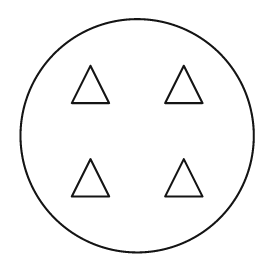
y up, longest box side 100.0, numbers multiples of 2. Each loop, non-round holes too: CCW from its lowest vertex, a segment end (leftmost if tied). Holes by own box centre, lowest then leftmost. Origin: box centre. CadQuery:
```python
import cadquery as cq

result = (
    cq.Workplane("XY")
    .moveTo(0.0, 0.0)
    .circle(50.0)
    .moveTo(-28.0, -26.0)
    .lineTo(-12.0, -26.0)
    .lineTo(-20.0, -10.0)
    .close()
    .moveTo(12.0, -26.0)
    .lineTo(28.0, -26.0)
    .lineTo(20.0, -10.0)
    .close()
    .moveTo(-28.0, 14.0)
    .lineTo(-12.0, 14.0)
    .lineTo(-20.0, 30.0)
    .close()
    .moveTo(12.0, 14.0)
    .lineTo(28.0, 14.0)
    .lineTo(20.0, 30.0)
    .close()
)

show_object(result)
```